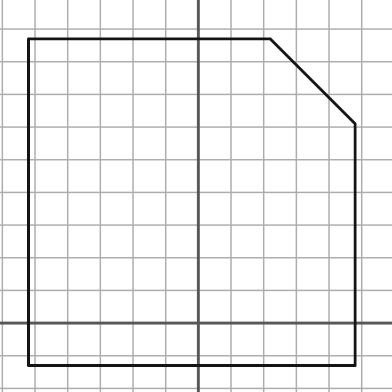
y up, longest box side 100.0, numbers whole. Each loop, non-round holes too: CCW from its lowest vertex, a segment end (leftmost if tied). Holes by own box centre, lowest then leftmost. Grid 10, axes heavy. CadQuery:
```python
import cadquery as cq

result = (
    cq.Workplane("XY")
    .moveTo(-52.0, -13.0)
    .lineTo(48.0, -13.0)
    .lineTo(48.0, 61.0)
    .lineTo(22.0, 87.0)
    .lineTo(-52.0, 87.0)
    .close()
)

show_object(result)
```